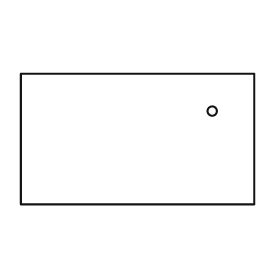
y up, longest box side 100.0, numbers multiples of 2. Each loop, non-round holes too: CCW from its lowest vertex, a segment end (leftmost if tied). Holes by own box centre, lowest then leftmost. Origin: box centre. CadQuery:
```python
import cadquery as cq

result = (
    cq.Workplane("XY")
    .moveTo(-50.0, -28.0)
    .lineTo(50.0, -28.0)
    .lineTo(50.0, 28.0)
    .lineTo(-50.0, 28.0)
    .close()
    .moveTo(32.0, 12.0)
    .circle(2.0)
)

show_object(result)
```